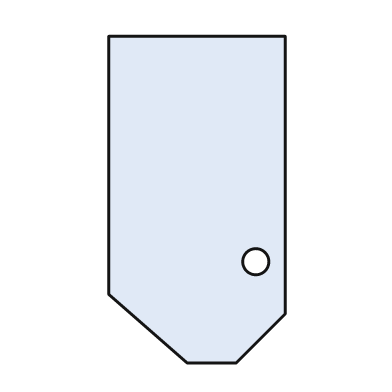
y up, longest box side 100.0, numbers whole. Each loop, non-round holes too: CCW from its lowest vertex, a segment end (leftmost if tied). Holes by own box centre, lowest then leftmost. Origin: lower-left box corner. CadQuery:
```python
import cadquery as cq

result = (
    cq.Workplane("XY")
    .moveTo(24.0, 0.0)
    .lineTo(39.0, 0.0)
    .lineTo(54.0, 15.0)
    .lineTo(54.0, 100.0)
    .lineTo(0.0, 100.0)
    .lineTo(0.0, 21.0)
    .close()
    .moveTo(45.0, 31.0)
    .circle(4.0)
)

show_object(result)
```